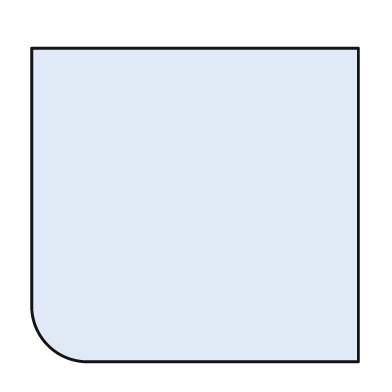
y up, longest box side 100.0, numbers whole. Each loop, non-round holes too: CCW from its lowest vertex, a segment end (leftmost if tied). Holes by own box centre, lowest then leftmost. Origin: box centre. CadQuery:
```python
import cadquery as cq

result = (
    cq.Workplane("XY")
    .moveTo(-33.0, -48.0)
    .lineTo(50.0, -48.0)
    .lineTo(50.0, 48.0)
    .lineTo(-50.0, 48.0)
    .lineTo(-50.0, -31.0)
    .threePointArc((-45.0, -43.0), (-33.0, -48.0))
    .close()
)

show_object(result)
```